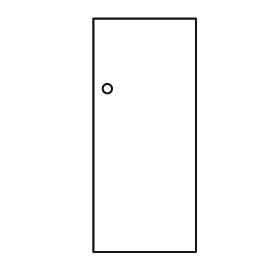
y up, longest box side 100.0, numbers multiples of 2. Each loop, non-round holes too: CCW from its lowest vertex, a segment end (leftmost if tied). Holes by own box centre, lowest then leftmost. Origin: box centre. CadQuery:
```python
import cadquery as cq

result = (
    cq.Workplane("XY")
    .moveTo(-22.0, -50.0)
    .lineTo(22.0, -50.0)
    .lineTo(22.0, 50.0)
    .lineTo(-22.0, 50.0)
    .close()
    .moveTo(-16.0, 20.0)
    .circle(2.0)
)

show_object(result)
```